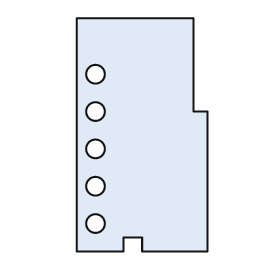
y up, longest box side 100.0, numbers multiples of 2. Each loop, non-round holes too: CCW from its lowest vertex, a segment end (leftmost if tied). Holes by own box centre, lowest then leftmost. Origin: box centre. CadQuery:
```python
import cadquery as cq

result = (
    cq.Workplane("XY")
    .moveTo(-28.0, -50.0)
    .lineTo(-8.0, -50.0)
    .lineTo(-8.0, -44.0)
    .lineTo(0.0, -44.0)
    .lineTo(0.0, -50.0)
    .lineTo(28.0, -50.0)
    .lineTo(28.0, 10.0)
    .lineTo(22.0, 10.0)
    .lineTo(22.0, 50.0)
    .lineTo(-28.0, 50.0)
    .close()
    .moveTo(-20.0, -38.0)
    .circle(4.0)
    .moveTo(-20.0, -22.0)
    .circle(4.0)
    .moveTo(-20.0, -6.0)
    .circle(4.0)
    .moveTo(-20.0, 10.0)
    .circle(4.0)
    .moveTo(-20.0, 26.0)
    .circle(4.0)
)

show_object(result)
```